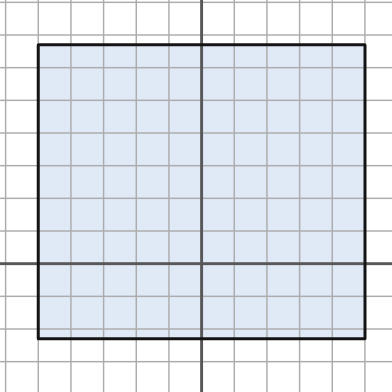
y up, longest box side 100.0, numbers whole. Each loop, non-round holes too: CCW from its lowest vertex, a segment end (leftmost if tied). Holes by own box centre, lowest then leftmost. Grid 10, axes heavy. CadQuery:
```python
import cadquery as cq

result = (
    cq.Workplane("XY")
    .moveTo(-50.0, -23.0)
    .lineTo(50.0, -23.0)
    .lineTo(50.0, 67.0)
    .lineTo(-50.0, 67.0)
    .close()
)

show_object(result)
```